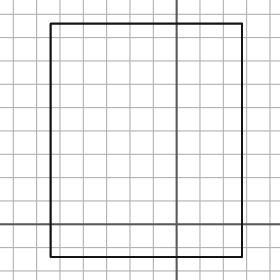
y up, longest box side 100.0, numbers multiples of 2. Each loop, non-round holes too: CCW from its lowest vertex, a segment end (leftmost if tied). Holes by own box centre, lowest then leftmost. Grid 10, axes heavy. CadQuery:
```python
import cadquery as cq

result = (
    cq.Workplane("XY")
    .moveTo(-54.0, -14.0)
    .lineTo(28.0, -14.0)
    .lineTo(28.0, 86.0)
    .lineTo(-54.0, 86.0)
    .close()
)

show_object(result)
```